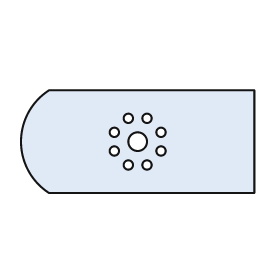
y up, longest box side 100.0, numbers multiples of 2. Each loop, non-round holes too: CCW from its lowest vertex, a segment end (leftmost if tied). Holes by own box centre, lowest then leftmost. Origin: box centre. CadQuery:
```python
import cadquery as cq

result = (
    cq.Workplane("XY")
    .moveTo(-38.0, -22.0)
    .lineTo(50.0, -22.0)
    .lineTo(50.0, 22.0)
    .lineTo(-38.0, 22.0)
    .threePointArc((-50.0, 0.0), (-38.0, -22.0))
    .close()
    .moveTo(-4.0, -10.0)
    .circle(2.0)
    .moveTo(4.0, -10.0)
    .circle(2.0)
    .moveTo(-10.0, -4.0)
    .circle(2.0)
    .moveTo(10.0, -4.0)
    .circle(2.0)
    .moveTo(0.0, 0.0)
    .circle(4.0)
    .moveTo(-10.0, 4.0)
    .circle(2.0)
    .moveTo(10.0, 4.0)
    .circle(2.0)
    .moveTo(-4.0, 10.0)
    .circle(2.0)
    .moveTo(4.0, 10.0)
    .circle(2.0)
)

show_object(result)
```